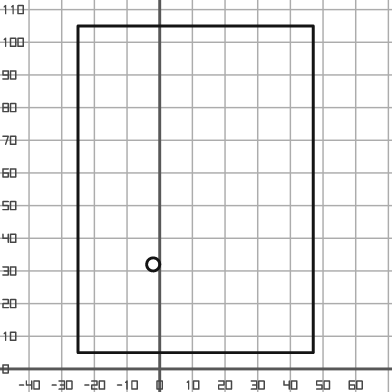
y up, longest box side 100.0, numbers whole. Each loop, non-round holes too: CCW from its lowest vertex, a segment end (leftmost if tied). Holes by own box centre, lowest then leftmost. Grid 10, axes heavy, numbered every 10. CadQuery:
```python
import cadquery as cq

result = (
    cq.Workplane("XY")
    .moveTo(-25.0, 5.0)
    .lineTo(47.0, 5.0)
    .lineTo(47.0, 105.0)
    .lineTo(-25.0, 105.0)
    .close()
    .moveTo(-2.0, 32.0)
    .circle(2.0)
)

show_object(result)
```